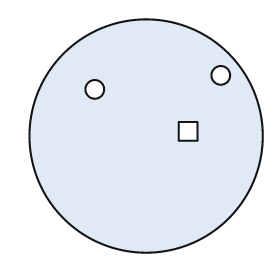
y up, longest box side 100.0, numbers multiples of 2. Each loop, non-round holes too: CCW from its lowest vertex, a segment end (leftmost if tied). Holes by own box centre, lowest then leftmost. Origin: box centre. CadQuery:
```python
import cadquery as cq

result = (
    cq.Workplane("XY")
    .moveTo(0.0, 0.0)
    .circle(50.0)
    .moveTo(14.0, -2.0)
    .lineTo(22.0, -2.0)
    .lineTo(22.0, 6.0)
    .lineTo(14.0, 6.0)
    .close()
    .moveTo(-22.0, 20.0)
    .circle(4.0)
    .moveTo(32.0, 26.0)
    .circle(4.0)
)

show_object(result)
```